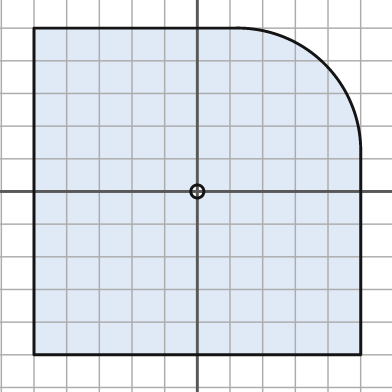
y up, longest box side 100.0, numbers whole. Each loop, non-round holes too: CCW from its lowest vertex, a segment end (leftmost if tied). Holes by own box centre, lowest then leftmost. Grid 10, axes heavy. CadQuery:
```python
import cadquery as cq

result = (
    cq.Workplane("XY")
    .moveTo(-50.0, -50.0)
    .lineTo(50.0, -50.0)
    .lineTo(50.0, 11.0)
    .threePointArc((39.0, 39.0), (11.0, 50.0))
    .lineTo(-50.0, 50.0)
    .close()
    .moveTo(0.0, 0.0)
    .circle(2.0)
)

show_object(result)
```